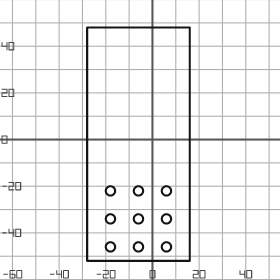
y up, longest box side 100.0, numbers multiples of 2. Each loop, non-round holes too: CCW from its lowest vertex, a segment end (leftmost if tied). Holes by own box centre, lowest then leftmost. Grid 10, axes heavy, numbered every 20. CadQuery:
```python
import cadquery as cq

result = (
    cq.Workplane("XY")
    .moveTo(-28.0, -52.0)
    .lineTo(16.0, -52.0)
    .lineTo(16.0, 48.0)
    .lineTo(-28.0, 48.0)
    .close()
    .moveTo(-18.0, -46.0)
    .circle(2.0)
    .moveTo(-6.0, -46.0)
    .circle(2.0)
    .moveTo(6.0, -46.0)
    .circle(2.0)
    .moveTo(-18.0, -34.0)
    .circle(2.0)
    .moveTo(-6.0, -34.0)
    .circle(2.0)
    .moveTo(6.0, -34.0)
    .circle(2.0)
    .moveTo(-18.0, -22.0)
    .circle(2.0)
    .moveTo(-6.0, -22.0)
    .circle(2.0)
    .moveTo(6.0, -22.0)
    .circle(2.0)
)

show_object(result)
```